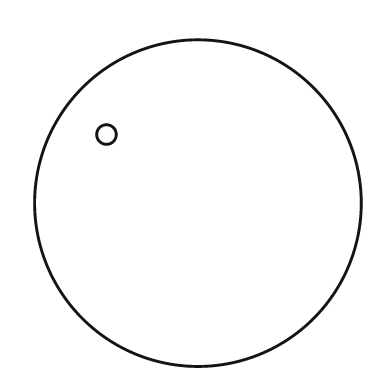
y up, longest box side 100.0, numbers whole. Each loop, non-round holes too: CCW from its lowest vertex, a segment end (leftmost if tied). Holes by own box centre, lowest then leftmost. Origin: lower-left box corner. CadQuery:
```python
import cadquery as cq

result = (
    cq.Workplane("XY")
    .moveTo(50.0, 50.0)
    .circle(50.0)
    .moveTo(22.0, 71.0)
    .circle(3.0)
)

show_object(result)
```